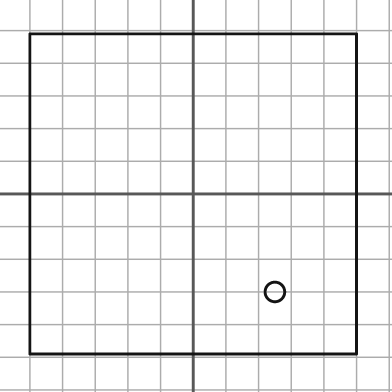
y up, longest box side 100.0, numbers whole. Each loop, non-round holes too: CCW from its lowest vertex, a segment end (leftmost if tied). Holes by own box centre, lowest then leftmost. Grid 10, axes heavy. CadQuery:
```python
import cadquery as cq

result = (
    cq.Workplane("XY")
    .moveTo(-50.0, -49.0)
    .lineTo(50.0, -49.0)
    .lineTo(50.0, 49.0)
    .lineTo(-50.0, 49.0)
    .close()
    .moveTo(25.0, -30.0)
    .circle(3.0)
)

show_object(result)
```